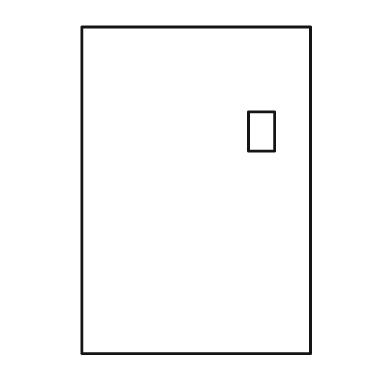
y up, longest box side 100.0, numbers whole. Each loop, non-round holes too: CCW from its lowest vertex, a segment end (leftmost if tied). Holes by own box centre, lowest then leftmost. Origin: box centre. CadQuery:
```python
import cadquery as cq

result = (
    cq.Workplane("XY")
    .moveTo(-35.0, -50.0)
    .lineTo(35.0, -50.0)
    .lineTo(35.0, 50.0)
    .lineTo(-35.0, 50.0)
    .close()
    .moveTo(16.0, 12.0)
    .lineTo(24.0, 12.0)
    .lineTo(24.0, 24.0)
    .lineTo(16.0, 24.0)
    .close()
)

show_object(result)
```